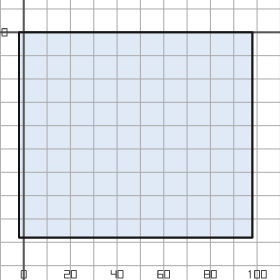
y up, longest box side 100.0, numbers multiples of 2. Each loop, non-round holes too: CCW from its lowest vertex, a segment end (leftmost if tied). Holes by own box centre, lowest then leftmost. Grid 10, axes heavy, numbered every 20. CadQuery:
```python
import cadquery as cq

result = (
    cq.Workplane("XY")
    .moveTo(-2.0, -88.0)
    .lineTo(98.0, -88.0)
    .lineTo(98.0, 0.0)
    .lineTo(-2.0, 0.0)
    .close()
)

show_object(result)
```